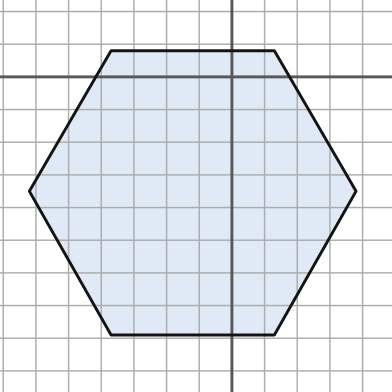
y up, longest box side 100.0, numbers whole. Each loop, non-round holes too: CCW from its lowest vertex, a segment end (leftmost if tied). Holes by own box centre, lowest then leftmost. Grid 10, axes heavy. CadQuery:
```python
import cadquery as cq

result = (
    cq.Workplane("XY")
    .moveTo(-37.0, -79.0)
    .lineTo(13.0, -79.0)
    .lineTo(38.0, -35.0)
    .lineTo(13.0, 8.0)
    .lineTo(-37.0, 8.0)
    .lineTo(-62.0, -35.0)
    .close()
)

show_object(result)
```